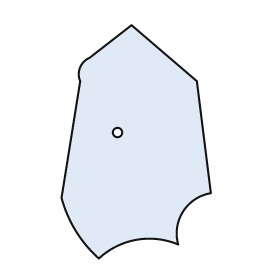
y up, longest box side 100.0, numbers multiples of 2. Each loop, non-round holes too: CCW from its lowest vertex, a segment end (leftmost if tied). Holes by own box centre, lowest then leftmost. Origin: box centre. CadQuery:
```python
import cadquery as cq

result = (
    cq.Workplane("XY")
    .moveTo(-16.0, -50.0)
    .threePointArc((0.0, -42.0), (18.0, -44.0))
    .threePointArc((20.0, -30.0), (32.0, -22.0))
    .lineTo(26.0, 26.0)
    .lineTo(-2.0, 50.0)
    .lineTo(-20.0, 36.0)
    .threePointArc((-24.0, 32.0), (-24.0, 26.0))
    .lineTo(-32.0, -24.0)
    .threePointArc((-26.0, -38.0), (-16.0, -50.0))
    .close()
    .moveTo(-8.0, 4.0)
    .circle(2.0)
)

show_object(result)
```